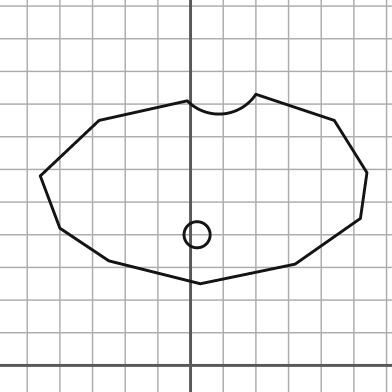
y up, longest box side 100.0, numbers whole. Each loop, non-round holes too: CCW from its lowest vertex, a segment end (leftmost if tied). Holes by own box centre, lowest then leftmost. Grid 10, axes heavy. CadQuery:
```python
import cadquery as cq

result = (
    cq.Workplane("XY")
    .moveTo(3.0, 25.0)
    .lineTo(32.0, 31.0)
    .lineTo(52.0, 45.0)
    .lineTo(54.0, 59.0)
    .lineTo(44.0, 75.0)
    .lineTo(20.0, 83.0)
    .threePointArc((10.0, 77.0), (-1.0, 81.0))
    .lineTo(-28.0, 75.0)
    .lineTo(-46.0, 58.0)
    .lineTo(-40.0, 42.0)
    .lineTo(-25.0, 32.0)
    .close()
    .moveTo(2.0, 40.0)
    .circle(4.0)
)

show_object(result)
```